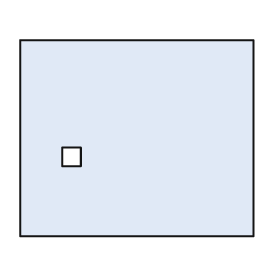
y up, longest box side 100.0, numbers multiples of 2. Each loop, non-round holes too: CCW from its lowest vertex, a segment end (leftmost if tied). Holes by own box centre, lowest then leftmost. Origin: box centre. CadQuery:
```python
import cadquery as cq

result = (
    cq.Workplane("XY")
    .moveTo(-50.0, -42.0)
    .lineTo(50.0, -42.0)
    .lineTo(50.0, 42.0)
    .lineTo(-50.0, 42.0)
    .close()
    .moveTo(-32.0, -12.0)
    .lineTo(-24.0, -12.0)
    .lineTo(-24.0, -4.0)
    .lineTo(-32.0, -4.0)
    .close()
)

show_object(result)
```